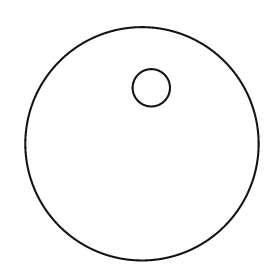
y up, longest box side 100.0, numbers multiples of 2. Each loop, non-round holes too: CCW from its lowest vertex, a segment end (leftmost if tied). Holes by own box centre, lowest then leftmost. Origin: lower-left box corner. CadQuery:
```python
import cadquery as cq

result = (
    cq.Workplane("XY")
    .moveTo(50.0, 50.0)
    .circle(50.0)
    .moveTo(54.0, 74.0)
    .circle(8.0)
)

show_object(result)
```